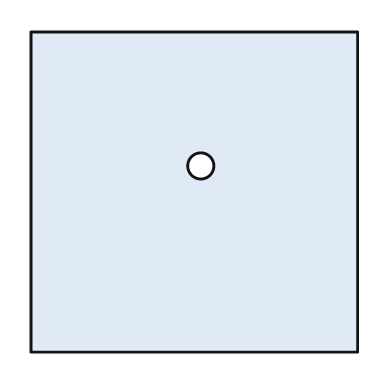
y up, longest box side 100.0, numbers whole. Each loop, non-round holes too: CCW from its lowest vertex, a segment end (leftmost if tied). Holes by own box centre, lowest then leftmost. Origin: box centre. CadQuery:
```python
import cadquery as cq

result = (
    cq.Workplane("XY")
    .moveTo(-50.0, -49.0)
    .lineTo(50.0, -49.0)
    .lineTo(50.0, 49.0)
    .lineTo(-50.0, 49.0)
    .close()
    .moveTo(2.0, 8.0)
    .circle(4.0)
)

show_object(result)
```